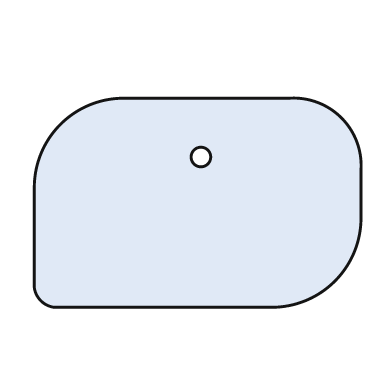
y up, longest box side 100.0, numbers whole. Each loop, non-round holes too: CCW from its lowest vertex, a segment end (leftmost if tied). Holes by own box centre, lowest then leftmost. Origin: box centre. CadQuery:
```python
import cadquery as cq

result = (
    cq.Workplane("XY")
    .moveTo(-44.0, -32.0)
    .lineTo(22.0, -32.0)
    .threePointArc((42.0, -24.0), (50.0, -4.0))
    .lineTo(50.0, 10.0)
    .threePointArc((44.0, 26.0), (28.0, 32.0))
    .lineTo(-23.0, 32.0)
    .threePointArc((-42.0, 24.0), (-50.0, 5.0))
    .lineTo(-50.0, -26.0)
    .threePointArc((-48.0, -30.0), (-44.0, -32.0))
    .close()
    .moveTo(1.0, 14.0)
    .circle(3.0)
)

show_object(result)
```